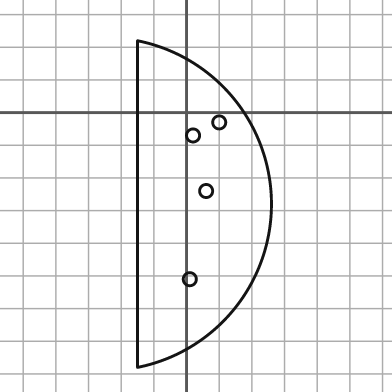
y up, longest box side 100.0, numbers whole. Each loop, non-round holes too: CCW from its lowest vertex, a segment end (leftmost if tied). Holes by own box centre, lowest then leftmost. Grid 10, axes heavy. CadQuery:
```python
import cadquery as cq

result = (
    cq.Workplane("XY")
    .moveTo(-15.0, -78.0)
    .threePointArc((26.0, -28.0), (-15.0, 22.0))
    .close()
    .moveTo(1.0, -51.0)
    .circle(2.0)
    .moveTo(6.0, -24.0)
    .circle(2.0)
    .moveTo(2.0, -7.0)
    .circle(2.0)
    .moveTo(10.0, -3.0)
    .circle(2.0)
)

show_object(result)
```